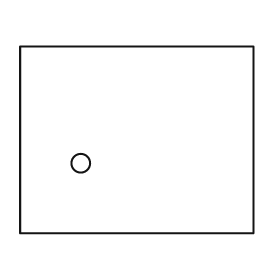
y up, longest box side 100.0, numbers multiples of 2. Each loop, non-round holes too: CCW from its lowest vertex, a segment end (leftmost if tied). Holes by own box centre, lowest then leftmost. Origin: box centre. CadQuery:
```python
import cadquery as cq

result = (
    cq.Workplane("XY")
    .moveTo(-50.0, -40.0)
    .lineTo(50.0, -40.0)
    .lineTo(50.0, 40.0)
    .lineTo(-50.0, 40.0)
    .close()
    .moveTo(-24.0, -10.0)
    .circle(4.0)
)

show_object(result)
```